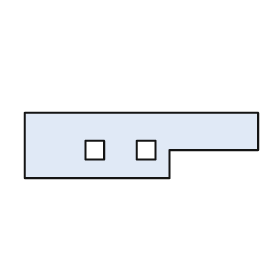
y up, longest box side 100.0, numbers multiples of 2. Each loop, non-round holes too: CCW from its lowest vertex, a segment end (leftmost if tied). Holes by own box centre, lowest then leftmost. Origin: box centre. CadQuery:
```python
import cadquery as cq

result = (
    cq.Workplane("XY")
    .moveTo(-50.0, -14.0)
    .lineTo(12.0, -14.0)
    .lineTo(12.0, -2.0)
    .lineTo(50.0, -2.0)
    .lineTo(50.0, 14.0)
    .lineTo(-50.0, 14.0)
    .close()
    .moveTo(-24.0, -6.0)
    .lineTo(-16.0, -6.0)
    .lineTo(-16.0, 2.0)
    .lineTo(-24.0, 2.0)
    .close()
    .moveTo(-2.0, -6.0)
    .lineTo(6.0, -6.0)
    .lineTo(6.0, 2.0)
    .lineTo(-2.0, 2.0)
    .close()
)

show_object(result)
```